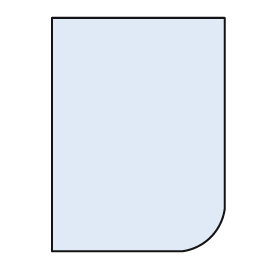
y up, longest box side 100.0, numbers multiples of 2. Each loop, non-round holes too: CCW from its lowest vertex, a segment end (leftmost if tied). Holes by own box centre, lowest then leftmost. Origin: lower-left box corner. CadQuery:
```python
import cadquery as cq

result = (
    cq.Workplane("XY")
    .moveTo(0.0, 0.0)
    .lineTo(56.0, 0.0)
    .threePointArc((68.0, 6.0), (74.0, 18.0))
    .lineTo(74.0, 100.0)
    .lineTo(0.0, 100.0)
    .close()
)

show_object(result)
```